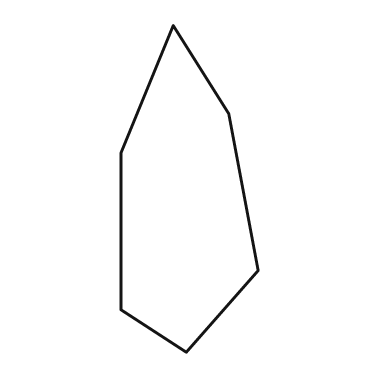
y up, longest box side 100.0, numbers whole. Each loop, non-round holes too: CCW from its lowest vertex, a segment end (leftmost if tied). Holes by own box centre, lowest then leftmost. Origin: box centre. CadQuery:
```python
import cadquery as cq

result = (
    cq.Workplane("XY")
    .moveTo(-1.0, -50.0)
    .lineTo(21.0, -25.0)
    .lineTo(12.0, 23.0)
    .lineTo(-5.0, 50.0)
    .lineTo(-21.0, 11.0)
    .lineTo(-21.0, -37.0)
    .close()
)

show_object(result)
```